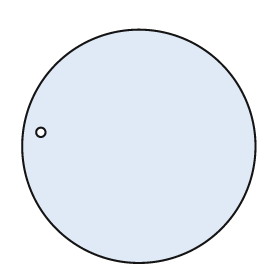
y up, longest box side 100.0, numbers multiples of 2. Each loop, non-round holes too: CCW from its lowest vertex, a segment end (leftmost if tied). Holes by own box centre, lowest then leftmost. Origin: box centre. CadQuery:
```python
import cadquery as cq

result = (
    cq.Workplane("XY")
    .moveTo(0.0, 0.0)
    .circle(50.0)
    .moveTo(-42.0, 6.0)
    .circle(2.0)
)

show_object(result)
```